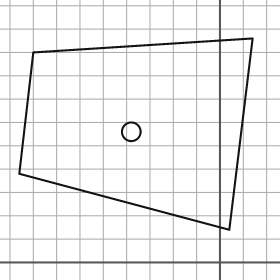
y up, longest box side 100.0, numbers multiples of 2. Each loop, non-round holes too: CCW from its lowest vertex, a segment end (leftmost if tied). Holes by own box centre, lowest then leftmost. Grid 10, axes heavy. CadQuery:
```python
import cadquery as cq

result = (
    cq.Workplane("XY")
    .moveTo(4.0, 14.0)
    .lineTo(14.0, 96.0)
    .lineTo(-80.0, 90.0)
    .lineTo(-86.0, 38.0)
    .close()
    .moveTo(-38.0, 56.0)
    .circle(4.0)
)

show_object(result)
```